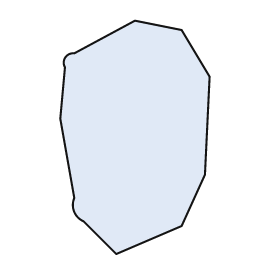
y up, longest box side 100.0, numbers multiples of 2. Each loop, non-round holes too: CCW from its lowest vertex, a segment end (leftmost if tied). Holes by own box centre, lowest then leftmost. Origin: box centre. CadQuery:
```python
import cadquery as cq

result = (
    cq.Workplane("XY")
    .moveTo(-8.0, -50.0)
    .lineTo(20.0, -38.0)
    .lineTo(30.0, -16.0)
    .lineTo(32.0, 26.0)
    .lineTo(20.0, 46.0)
    .lineTo(0.0, 50.0)
    .lineTo(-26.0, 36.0)
    .threePointArc((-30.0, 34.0), (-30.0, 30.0))
    .lineTo(-32.0, 8.0)
    .lineTo(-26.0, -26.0)
    .threePointArc((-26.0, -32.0), (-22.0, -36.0))
    .close()
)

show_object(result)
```